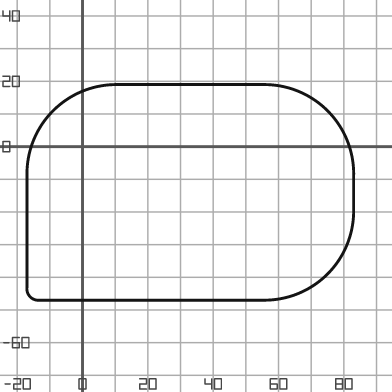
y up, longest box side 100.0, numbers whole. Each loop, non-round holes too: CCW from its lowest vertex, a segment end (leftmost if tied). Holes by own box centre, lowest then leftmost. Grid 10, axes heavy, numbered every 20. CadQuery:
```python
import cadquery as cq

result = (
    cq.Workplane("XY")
    .moveTo(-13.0, -47.0)
    .lineTo(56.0, -47.0)
    .threePointArc((75.0, -39.0), (83.0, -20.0))
    .lineTo(83.0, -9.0)
    .threePointArc((75.0, 11.0), (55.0, 19.0))
    .lineTo(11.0, 19.0)
    .threePointArc((-9.0, 11.0), (-17.0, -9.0))
    .lineTo(-17.0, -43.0)
    .threePointArc((-16.0, -46.0), (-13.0, -47.0))
    .close()
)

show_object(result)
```